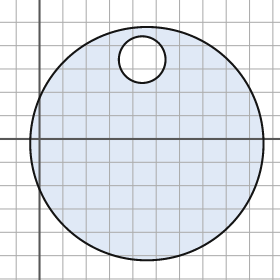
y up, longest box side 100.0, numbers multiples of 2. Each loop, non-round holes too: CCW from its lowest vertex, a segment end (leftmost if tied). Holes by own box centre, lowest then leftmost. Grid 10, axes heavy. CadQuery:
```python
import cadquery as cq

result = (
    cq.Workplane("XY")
    .moveTo(46.0, -2.0)
    .circle(50.0)
    .moveTo(44.0, 34.0)
    .circle(10.0)
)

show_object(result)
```